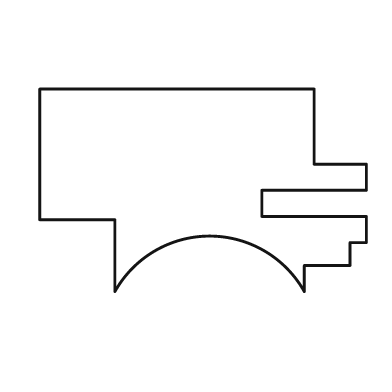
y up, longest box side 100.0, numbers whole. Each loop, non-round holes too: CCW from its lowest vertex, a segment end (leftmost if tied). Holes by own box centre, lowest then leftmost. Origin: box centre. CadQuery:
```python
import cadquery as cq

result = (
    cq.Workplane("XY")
    .moveTo(-27.0, -31.0)
    .threePointArc((2.0, -14.0), (31.0, -31.0))
    .lineTo(31.0, -23.0)
    .lineTo(45.0, -23.0)
    .lineTo(45.0, -16.0)
    .lineTo(50.0, -16.0)
    .lineTo(50.0, -8.0)
    .lineTo(18.0, -8.0)
    .lineTo(18.0, 0.0)
    .lineTo(50.0, 0.0)
    .lineTo(50.0, 8.0)
    .lineTo(34.0, 8.0)
    .lineTo(34.0, 31.0)
    .lineTo(-50.0, 31.0)
    .lineTo(-50.0, -9.0)
    .lineTo(-27.0, -9.0)
    .close()
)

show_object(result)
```